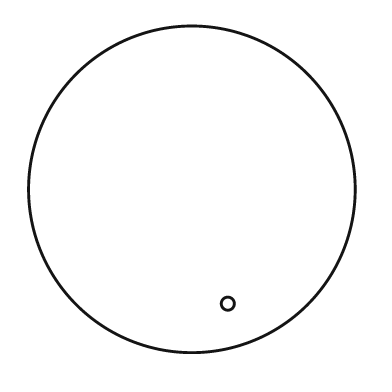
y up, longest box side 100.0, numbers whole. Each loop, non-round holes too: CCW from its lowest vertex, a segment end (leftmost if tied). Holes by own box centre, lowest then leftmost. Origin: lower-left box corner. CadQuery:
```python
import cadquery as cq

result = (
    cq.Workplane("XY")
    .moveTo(50.0, 50.0)
    .circle(50.0)
    .moveTo(61.0, 15.0)
    .circle(2.0)
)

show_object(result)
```